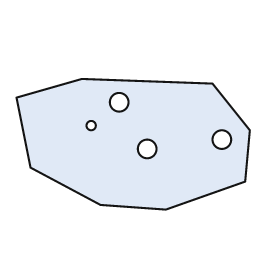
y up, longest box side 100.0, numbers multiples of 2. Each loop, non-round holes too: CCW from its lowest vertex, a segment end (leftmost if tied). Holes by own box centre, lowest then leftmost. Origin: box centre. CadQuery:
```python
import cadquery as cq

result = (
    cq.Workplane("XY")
    .moveTo(14.0, -28.0)
    .lineTo(48.0, -16.0)
    .lineTo(50.0, 6.0)
    .lineTo(34.0, 26.0)
    .lineTo(-22.0, 28.0)
    .lineTo(-50.0, 20.0)
    .lineTo(-44.0, -10.0)
    .lineTo(-14.0, -26.0)
    .close()
    .moveTo(6.0, -2.0)
    .circle(4.0)
    .moveTo(38.0, 2.0)
    .circle(4.0)
    .moveTo(-18.0, 8.0)
    .circle(2.0)
    .moveTo(-6.0, 18.0)
    .circle(4.0)
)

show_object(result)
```